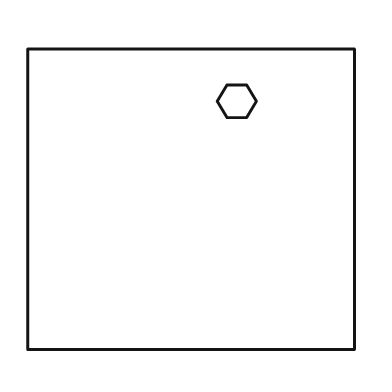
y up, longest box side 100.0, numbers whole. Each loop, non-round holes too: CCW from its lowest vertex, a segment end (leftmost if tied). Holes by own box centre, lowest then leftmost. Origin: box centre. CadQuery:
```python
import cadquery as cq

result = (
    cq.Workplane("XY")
    .moveTo(-50.0, -46.0)
    .lineTo(50.0, -46.0)
    .lineTo(50.0, 46.0)
    .lineTo(-50.0, 46.0)
    .close()
    .moveTo(11.0, 25.0)
    .lineTo(17.0, 25.0)
    .lineTo(20.0, 30.0)
    .lineTo(17.0, 35.0)
    .lineTo(11.0, 35.0)
    .lineTo(8.0, 30.0)
    .close()
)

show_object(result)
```